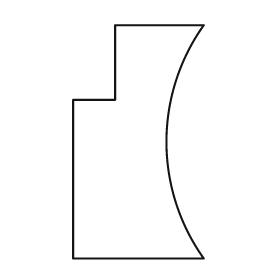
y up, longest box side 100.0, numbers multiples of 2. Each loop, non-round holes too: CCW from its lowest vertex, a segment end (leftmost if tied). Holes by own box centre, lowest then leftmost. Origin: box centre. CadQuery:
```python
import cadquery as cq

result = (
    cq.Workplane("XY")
    .moveTo(-28.0, -50.0)
    .lineTo(28.0, -50.0)
    .threePointArc((12.0, 0.0), (28.0, 50.0))
    .lineTo(-10.0, 50.0)
    .lineTo(-10.0, 18.0)
    .lineTo(-28.0, 18.0)
    .close()
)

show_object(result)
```